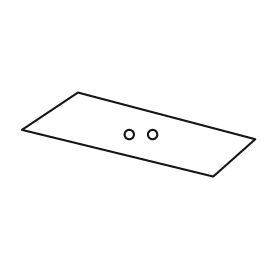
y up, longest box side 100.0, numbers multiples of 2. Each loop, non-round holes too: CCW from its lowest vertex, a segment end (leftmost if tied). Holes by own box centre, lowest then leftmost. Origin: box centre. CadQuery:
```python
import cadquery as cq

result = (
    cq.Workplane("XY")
    .moveTo(32.0, -18.0)
    .lineTo(50.0, -2.0)
    .lineTo(-26.0, 18.0)
    .lineTo(-50.0, 2.0)
    .close()
    .moveTo(-4.0, 0.0)
    .circle(2.0)
    .moveTo(6.0, 0.0)
    .circle(2.0)
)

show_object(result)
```